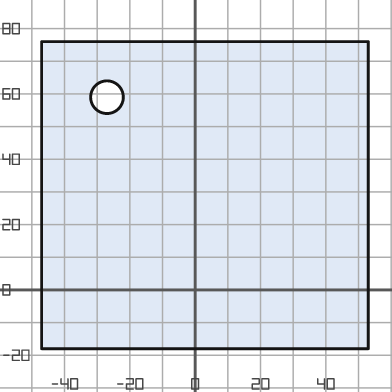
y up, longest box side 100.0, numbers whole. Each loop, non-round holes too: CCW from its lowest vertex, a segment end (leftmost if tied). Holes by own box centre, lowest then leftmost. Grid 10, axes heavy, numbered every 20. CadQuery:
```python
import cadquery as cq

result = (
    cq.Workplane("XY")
    .moveTo(-47.0, -18.0)
    .lineTo(53.0, -18.0)
    .lineTo(53.0, 76.0)
    .lineTo(-47.0, 76.0)
    .close()
    .moveTo(-27.0, 59.0)
    .circle(5.0)
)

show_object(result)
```